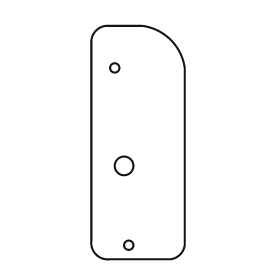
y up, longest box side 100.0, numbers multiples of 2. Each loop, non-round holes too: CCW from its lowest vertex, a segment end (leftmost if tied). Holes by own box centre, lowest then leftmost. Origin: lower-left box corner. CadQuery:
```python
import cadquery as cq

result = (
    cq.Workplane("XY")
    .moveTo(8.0, 0.0)
    .lineTo(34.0, 0.0)
    .threePointArc((38.0, 2.0), (40.0, 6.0))
    .lineTo(40.0, 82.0)
    .threePointArc((34.0, 94.0), (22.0, 100.0))
    .lineTo(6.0, 100.0)
    .threePointArc((2.0, 98.0), (0.0, 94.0))
    .lineTo(0.0, 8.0)
    .threePointArc((2.0, 2.0), (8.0, 0.0))
    .close()
    .moveTo(16.0, 6.0)
    .circle(2.0)
    .moveTo(14.0, 40.0)
    .circle(4.0)
    .moveTo(10.0, 82.0)
    .circle(2.0)
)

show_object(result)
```